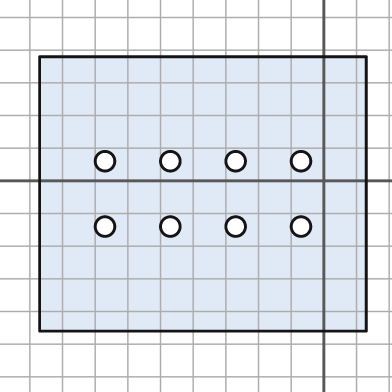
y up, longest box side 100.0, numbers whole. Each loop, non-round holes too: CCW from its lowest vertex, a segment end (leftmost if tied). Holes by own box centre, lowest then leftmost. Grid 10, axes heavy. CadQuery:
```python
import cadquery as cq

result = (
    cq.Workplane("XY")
    .moveTo(-87.0, -46.0)
    .lineTo(13.0, -46.0)
    .lineTo(13.0, 38.0)
    .lineTo(-87.0, 38.0)
    .close()
    .moveTo(-67.0, -14.0)
    .circle(3.0)
    .moveTo(-47.0, -14.0)
    .circle(3.0)
    .moveTo(-27.0, -14.0)
    .circle(3.0)
    .moveTo(-7.0, -14.0)
    .circle(3.0)
    .moveTo(-67.0, 6.0)
    .circle(3.0)
    .moveTo(-47.0, 6.0)
    .circle(3.0)
    .moveTo(-27.0, 6.0)
    .circle(3.0)
    .moveTo(-7.0, 6.0)
    .circle(3.0)
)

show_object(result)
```